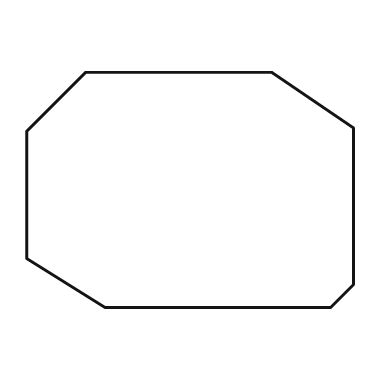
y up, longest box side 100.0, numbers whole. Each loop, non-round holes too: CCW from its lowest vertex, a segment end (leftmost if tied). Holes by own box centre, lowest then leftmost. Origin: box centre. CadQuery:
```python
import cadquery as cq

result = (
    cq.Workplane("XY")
    .moveTo(-26.0, -36.0)
    .lineTo(43.0, -36.0)
    .lineTo(50.0, -29.0)
    .lineTo(50.0, 19.0)
    .lineTo(25.0, 36.0)
    .lineTo(-32.0, 36.0)
    .lineTo(-50.0, 18.0)
    .lineTo(-50.0, -21.0)
    .close()
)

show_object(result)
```